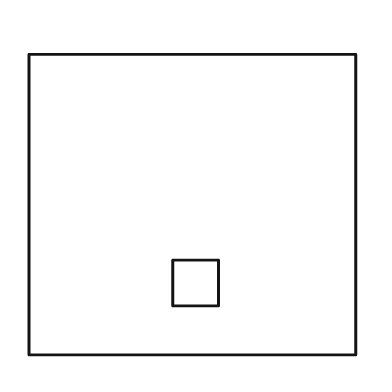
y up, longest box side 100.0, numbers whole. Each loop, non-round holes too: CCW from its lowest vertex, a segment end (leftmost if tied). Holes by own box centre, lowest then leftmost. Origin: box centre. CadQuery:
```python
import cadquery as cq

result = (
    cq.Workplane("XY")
    .moveTo(-50.0, -46.0)
    .lineTo(50.0, -46.0)
    .lineTo(50.0, 46.0)
    .lineTo(-50.0, 46.0)
    .close()
    .moveTo(-6.0, -31.0)
    .lineTo(8.0, -31.0)
    .lineTo(8.0, -17.0)
    .lineTo(-6.0, -17.0)
    .close()
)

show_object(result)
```